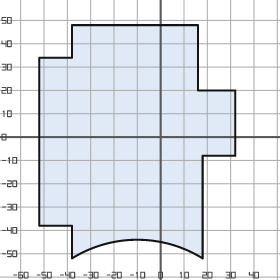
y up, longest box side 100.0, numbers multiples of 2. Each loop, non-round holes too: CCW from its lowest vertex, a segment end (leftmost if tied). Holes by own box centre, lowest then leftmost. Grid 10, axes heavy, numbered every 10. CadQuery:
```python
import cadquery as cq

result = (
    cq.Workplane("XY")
    .moveTo(-38.0, -52.0)
    .threePointArc((-10.0, -44.0), (18.0, -52.0))
    .lineTo(18.0, -8.0)
    .lineTo(32.0, -8.0)
    .lineTo(32.0, 20.0)
    .lineTo(16.0, 20.0)
    .lineTo(16.0, 48.0)
    .lineTo(-38.0, 48.0)
    .lineTo(-38.0, 34.0)
    .lineTo(-52.0, 34.0)
    .lineTo(-52.0, -38.0)
    .lineTo(-38.0, -38.0)
    .close()
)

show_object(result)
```